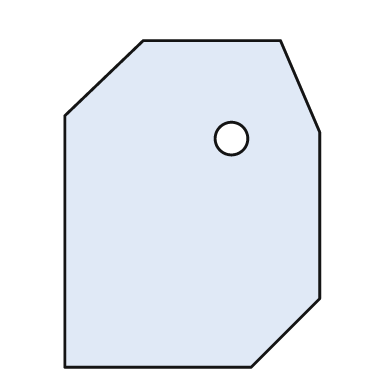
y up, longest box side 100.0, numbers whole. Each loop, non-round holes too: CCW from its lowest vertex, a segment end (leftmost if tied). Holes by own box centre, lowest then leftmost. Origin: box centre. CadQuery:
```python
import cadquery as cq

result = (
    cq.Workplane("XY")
    .moveTo(-39.0, -50.0)
    .lineTo(18.0, -50.0)
    .lineTo(39.0, -29.0)
    .lineTo(39.0, 22.0)
    .lineTo(27.0, 50.0)
    .lineTo(-15.0, 50.0)
    .lineTo(-39.0, 27.0)
    .close()
    .moveTo(12.0, 20.0)
    .circle(5.0)
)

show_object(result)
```